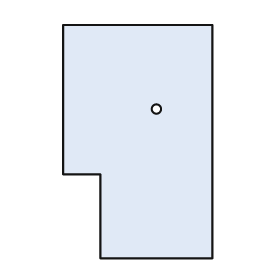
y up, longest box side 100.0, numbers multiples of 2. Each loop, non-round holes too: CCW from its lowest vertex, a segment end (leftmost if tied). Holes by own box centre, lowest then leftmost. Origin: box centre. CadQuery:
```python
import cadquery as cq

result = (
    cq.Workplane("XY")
    .moveTo(-16.0, -50.0)
    .lineTo(32.0, -50.0)
    .lineTo(32.0, 50.0)
    .lineTo(-32.0, 50.0)
    .lineTo(-32.0, -14.0)
    .lineTo(-16.0, -14.0)
    .close()
    .moveTo(8.0, 14.0)
    .circle(2.0)
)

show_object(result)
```